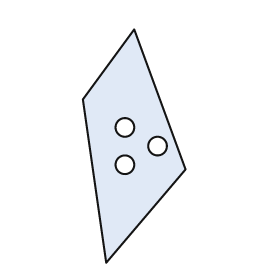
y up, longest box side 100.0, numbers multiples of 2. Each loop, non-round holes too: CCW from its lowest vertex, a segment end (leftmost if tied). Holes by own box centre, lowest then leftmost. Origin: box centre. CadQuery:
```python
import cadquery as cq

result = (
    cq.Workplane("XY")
    .moveTo(-12.0, -50.0)
    .lineTo(22.0, -10.0)
    .lineTo(0.0, 50.0)
    .lineTo(-22.0, 20.0)
    .close()
    .moveTo(-4.0, -8.0)
    .circle(4.0)
    .moveTo(10.0, 0.0)
    .circle(4.0)
    .moveTo(-4.0, 8.0)
    .circle(4.0)
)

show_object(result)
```